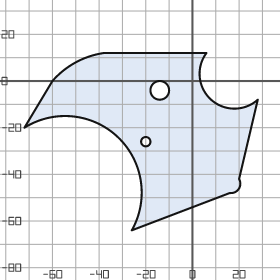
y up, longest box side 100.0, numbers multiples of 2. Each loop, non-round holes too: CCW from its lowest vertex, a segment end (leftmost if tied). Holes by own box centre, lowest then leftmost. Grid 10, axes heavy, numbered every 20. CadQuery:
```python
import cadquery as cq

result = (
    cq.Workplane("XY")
    .moveTo(-26.0, -64.0)
    .lineTo(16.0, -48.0)
    .threePointArc((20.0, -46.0), (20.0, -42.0))
    .lineTo(28.0, -8.0)
    .threePointArc((8.0, -8.0), (6.0, 12.0))
    .lineTo(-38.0, 12.0)
    .threePointArc((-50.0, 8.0), (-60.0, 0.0))
    .lineTo(-72.0, -20.0)
    .threePointArc((-32.0, -24.0), (-26.0, -64.0))
    .close()
    .moveTo(-20.0, -26.0)
    .circle(2.0)
    .moveTo(-14.0, -4.0)
    .circle(4.0)
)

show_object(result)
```